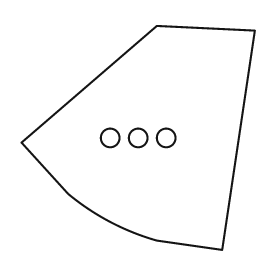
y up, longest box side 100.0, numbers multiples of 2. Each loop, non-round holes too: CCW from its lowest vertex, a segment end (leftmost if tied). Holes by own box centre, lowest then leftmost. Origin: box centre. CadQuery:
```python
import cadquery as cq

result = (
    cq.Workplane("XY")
    .moveTo(36.0, -48.0)
    .lineTo(50.0, 46.0)
    .lineTo(8.0, 48.0)
    .lineTo(-50.0, -2.0)
    .lineTo(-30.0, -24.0)
    .threePointArc((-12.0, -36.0), (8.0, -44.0))
    .close()
    .moveTo(-12.0, 0.0)
    .circle(4.0)
    .moveTo(0.0, 0.0)
    .circle(4.0)
    .moveTo(12.0, 0.0)
    .circle(4.0)
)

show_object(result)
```